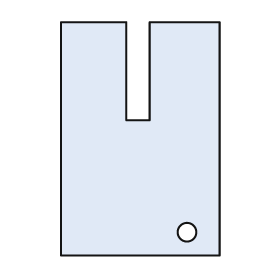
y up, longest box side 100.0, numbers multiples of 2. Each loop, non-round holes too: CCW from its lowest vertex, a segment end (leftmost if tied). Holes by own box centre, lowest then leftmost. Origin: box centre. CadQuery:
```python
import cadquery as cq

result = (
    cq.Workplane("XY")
    .moveTo(-34.0, -50.0)
    .lineTo(34.0, -50.0)
    .lineTo(34.0, 50.0)
    .lineTo(4.0, 50.0)
    .lineTo(4.0, 8.0)
    .lineTo(-6.0, 8.0)
    .lineTo(-6.0, 50.0)
    .lineTo(-34.0, 50.0)
    .close()
    .moveTo(20.0, -40.0)
    .circle(4.0)
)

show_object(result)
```